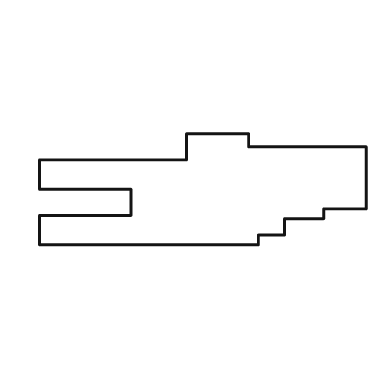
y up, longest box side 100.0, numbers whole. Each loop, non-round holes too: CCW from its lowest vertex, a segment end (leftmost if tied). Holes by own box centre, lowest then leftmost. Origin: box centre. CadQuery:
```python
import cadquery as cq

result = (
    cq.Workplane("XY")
    .moveTo(-50.0, -17.0)
    .lineTo(17.0, -17.0)
    .lineTo(17.0, -14.0)
    .lineTo(25.0, -14.0)
    .lineTo(25.0, -9.0)
    .lineTo(37.0, -9.0)
    .lineTo(37.0, -6.0)
    .lineTo(50.0, -6.0)
    .lineTo(50.0, 13.0)
    .lineTo(14.0, 13.0)
    .lineTo(14.0, 17.0)
    .lineTo(-5.0, 17.0)
    .lineTo(-5.0, 9.0)
    .lineTo(-50.0, 9.0)
    .lineTo(-50.0, 0.0)
    .lineTo(-22.0, 0.0)
    .lineTo(-22.0, -8.0)
    .lineTo(-50.0, -8.0)
    .close()
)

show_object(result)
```